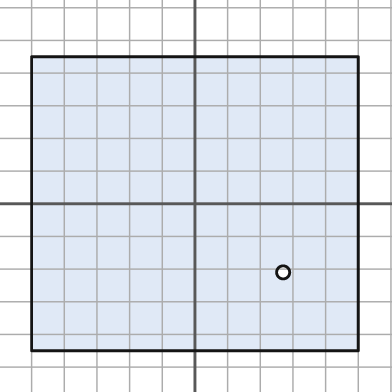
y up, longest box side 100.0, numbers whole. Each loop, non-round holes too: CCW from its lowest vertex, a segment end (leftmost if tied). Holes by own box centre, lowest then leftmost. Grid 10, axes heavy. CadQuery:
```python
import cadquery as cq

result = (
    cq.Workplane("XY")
    .moveTo(-50.0, -45.0)
    .lineTo(50.0, -45.0)
    .lineTo(50.0, 45.0)
    .lineTo(-50.0, 45.0)
    .close()
    .moveTo(27.0, -21.0)
    .circle(2.0)
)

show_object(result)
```